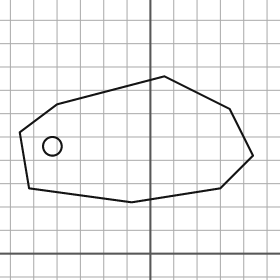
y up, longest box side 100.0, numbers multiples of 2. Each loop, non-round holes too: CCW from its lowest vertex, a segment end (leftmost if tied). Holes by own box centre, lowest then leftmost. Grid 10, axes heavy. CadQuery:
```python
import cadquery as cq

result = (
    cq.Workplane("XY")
    .moveTo(-8.0, 22.0)
    .lineTo(30.0, 28.0)
    .lineTo(44.0, 42.0)
    .lineTo(34.0, 62.0)
    .lineTo(6.0, 76.0)
    .lineTo(-40.0, 64.0)
    .lineTo(-56.0, 52.0)
    .lineTo(-52.0, 28.0)
    .close()
    .moveTo(-42.0, 46.0)
    .circle(4.0)
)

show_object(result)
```